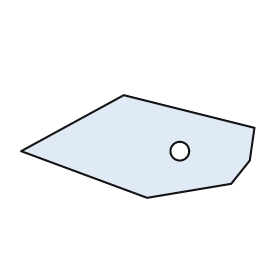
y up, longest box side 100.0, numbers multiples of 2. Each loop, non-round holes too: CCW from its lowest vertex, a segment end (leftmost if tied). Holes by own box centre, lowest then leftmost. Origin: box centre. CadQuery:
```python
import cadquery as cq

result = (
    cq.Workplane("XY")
    .moveTo(4.0, -22.0)
    .lineTo(40.0, -16.0)
    .lineTo(48.0, -6.0)
    .lineTo(50.0, 8.0)
    .lineTo(-6.0, 22.0)
    .lineTo(-50.0, -2.0)
    .close()
    .moveTo(18.0, -2.0)
    .circle(4.0)
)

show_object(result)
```